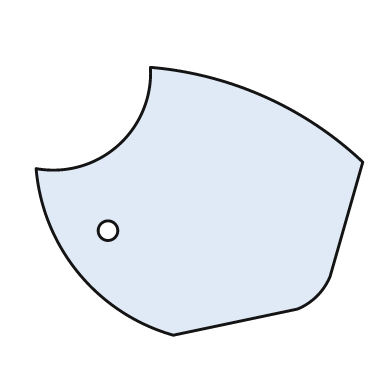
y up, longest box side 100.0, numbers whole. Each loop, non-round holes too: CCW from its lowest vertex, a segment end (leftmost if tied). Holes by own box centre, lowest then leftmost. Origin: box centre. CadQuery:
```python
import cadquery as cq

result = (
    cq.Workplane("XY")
    .moveTo(-8.0, -41.0)
    .lineTo(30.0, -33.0)
    .threePointArc((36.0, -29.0), (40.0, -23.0))
    .lineTo(50.0, 12.0)
    .threePointArc((20.0, 32.0), (-15.0, 41.0))
    .threePointArc((-25.0, 17.0), (-50.0, 10.0))
    .threePointArc((-37.0, -22.0), (-8.0, -41.0))
    .close()
    .moveTo(-28.0, -9.0)
    .circle(3.0)
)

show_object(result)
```